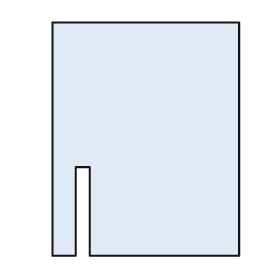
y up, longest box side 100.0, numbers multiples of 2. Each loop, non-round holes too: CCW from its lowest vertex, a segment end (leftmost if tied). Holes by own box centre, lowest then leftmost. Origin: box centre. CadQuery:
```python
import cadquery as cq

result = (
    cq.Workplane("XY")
    .moveTo(-40.0, -50.0)
    .lineTo(-30.0, -50.0)
    .lineTo(-30.0, -12.0)
    .lineTo(-24.0, -12.0)
    .lineTo(-24.0, -50.0)
    .lineTo(40.0, -50.0)
    .lineTo(40.0, 50.0)
    .lineTo(-40.0, 50.0)
    .close()
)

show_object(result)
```